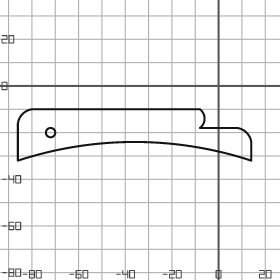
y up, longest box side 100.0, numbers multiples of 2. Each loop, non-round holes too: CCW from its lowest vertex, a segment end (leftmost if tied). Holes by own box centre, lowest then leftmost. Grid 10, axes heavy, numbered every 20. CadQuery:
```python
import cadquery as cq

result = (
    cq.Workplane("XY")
    .moveTo(-86.0, -32.0)
    .threePointArc((-36.0, -24.0), (14.0, -32.0))
    .lineTo(14.0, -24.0)
    .threePointArc((12.0, -20.0), (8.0, -18.0))
    .lineTo(-8.0, -18.0)
    .threePointArc((-6.0, -14.0), (-8.0, -10.0))
    .lineTo(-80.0, -10.0)
    .threePointArc((-84.0, -12.0), (-86.0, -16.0))
    .close()
    .moveTo(-72.0, -20.0)
    .circle(2.0)
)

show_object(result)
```